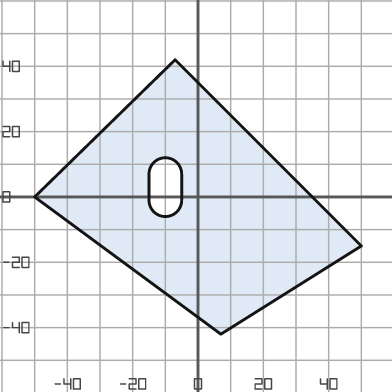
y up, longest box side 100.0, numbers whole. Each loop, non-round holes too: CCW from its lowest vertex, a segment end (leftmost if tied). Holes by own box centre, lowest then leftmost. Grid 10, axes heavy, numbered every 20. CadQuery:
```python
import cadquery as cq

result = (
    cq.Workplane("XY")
    .moveTo(7.0, -42.0)
    .lineTo(50.0, -15.0)
    .lineTo(-7.0, 42.0)
    .lineTo(-50.0, 0.0)
    .close()
    .moveTo(-15.0, -1.0)
    .threePointArc((-10.0, -6.0), (-5.0, -1.0))
    .lineTo(-5.0, 7.0)
    .threePointArc((-10.0, 12.0), (-15.0, 7.0))
    .close()
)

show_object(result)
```